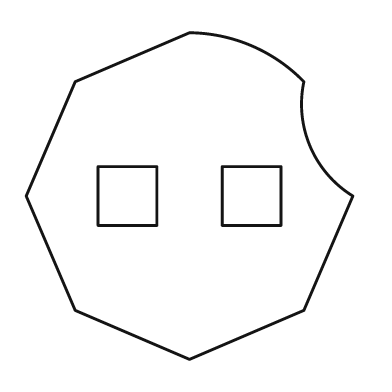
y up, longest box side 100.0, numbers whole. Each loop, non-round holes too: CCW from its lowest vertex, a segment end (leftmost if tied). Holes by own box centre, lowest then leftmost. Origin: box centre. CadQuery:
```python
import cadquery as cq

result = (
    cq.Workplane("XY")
    .moveTo(0.0, -50.0)
    .lineTo(35.0, -35.0)
    .lineTo(50.0, 0.0)
    .threePointArc((37.0, 15.0), (35.0, 35.0))
    .threePointArc((19.0, 46.0), (0.0, 50.0))
    .lineTo(-35.0, 35.0)
    .lineTo(-50.0, 0.0)
    .lineTo(-35.0, -35.0)
    .close()
    .moveTo(-28.0, -9.0)
    .lineTo(-10.0, -9.0)
    .lineTo(-10.0, 9.0)
    .lineTo(-28.0, 9.0)
    .close()
    .moveTo(10.0, -9.0)
    .lineTo(28.0, -9.0)
    .lineTo(28.0, 9.0)
    .lineTo(10.0, 9.0)
    .close()
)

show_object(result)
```